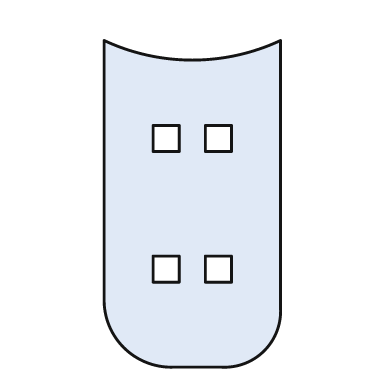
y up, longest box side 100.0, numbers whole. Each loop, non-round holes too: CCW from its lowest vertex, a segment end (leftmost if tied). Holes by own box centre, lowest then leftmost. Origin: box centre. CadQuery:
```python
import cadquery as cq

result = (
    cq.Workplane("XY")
    .moveTo(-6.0, -50.0)
    .lineTo(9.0, -50.0)
    .threePointArc((22.0, -45.0), (27.0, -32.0))
    .lineTo(27.0, 50.0)
    .threePointArc((0.0, 44.0), (-27.0, 50.0))
    .lineTo(-27.0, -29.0)
    .threePointArc((-21.0, -44.0), (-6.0, -50.0))
    .close()
    .moveTo(-12.0, -24.0)
    .lineTo(-4.0, -24.0)
    .lineTo(-4.0, -16.0)
    .lineTo(-12.0, -16.0)
    .close()
    .moveTo(4.0, -24.0)
    .lineTo(12.0, -24.0)
    .lineTo(12.0, -16.0)
    .lineTo(4.0, -16.0)
    .close()
    .moveTo(-12.0, 16.0)
    .lineTo(-4.0, 16.0)
    .lineTo(-4.0, 24.0)
    .lineTo(-12.0, 24.0)
    .close()
    .moveTo(4.0, 16.0)
    .lineTo(12.0, 16.0)
    .lineTo(12.0, 24.0)
    .lineTo(4.0, 24.0)
    .close()
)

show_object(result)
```